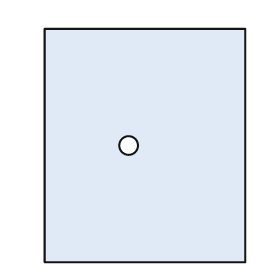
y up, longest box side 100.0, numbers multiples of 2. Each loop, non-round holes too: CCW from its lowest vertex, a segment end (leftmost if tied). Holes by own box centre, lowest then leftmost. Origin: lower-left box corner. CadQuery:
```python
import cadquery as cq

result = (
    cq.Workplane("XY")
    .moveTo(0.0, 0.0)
    .lineTo(86.0, 0.0)
    .lineTo(86.0, 100.0)
    .lineTo(0.0, 100.0)
    .close()
    .moveTo(36.0, 50.0)
    .circle(4.0)
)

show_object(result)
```